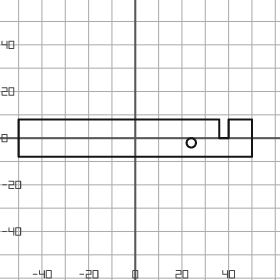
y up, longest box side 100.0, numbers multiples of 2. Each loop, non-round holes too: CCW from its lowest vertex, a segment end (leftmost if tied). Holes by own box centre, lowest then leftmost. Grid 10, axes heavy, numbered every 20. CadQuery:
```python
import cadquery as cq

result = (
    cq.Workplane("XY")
    .moveTo(-50.0, -8.0)
    .lineTo(50.0, -8.0)
    .lineTo(50.0, 8.0)
    .lineTo(40.0, 8.0)
    .lineTo(40.0, 0.0)
    .lineTo(36.0, 0.0)
    .lineTo(36.0, 8.0)
    .lineTo(-50.0, 8.0)
    .close()
    .moveTo(24.0, -2.0)
    .circle(2.0)
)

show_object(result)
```